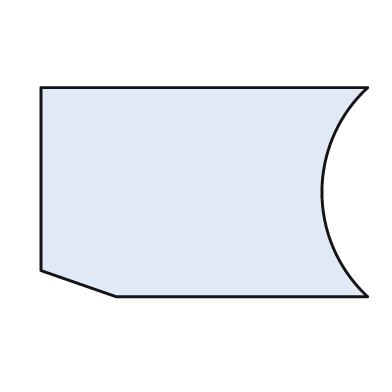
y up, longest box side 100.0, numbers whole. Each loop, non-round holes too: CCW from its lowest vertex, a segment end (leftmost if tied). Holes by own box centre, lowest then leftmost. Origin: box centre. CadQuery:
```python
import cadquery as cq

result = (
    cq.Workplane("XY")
    .moveTo(-27.0, -32.0)
    .lineTo(50.0, -32.0)
    .threePointArc((36.0, 0.0), (50.0, 32.0))
    .lineTo(-50.0, 32.0)
    .lineTo(-50.0, -24.0)
    .close()
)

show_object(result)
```